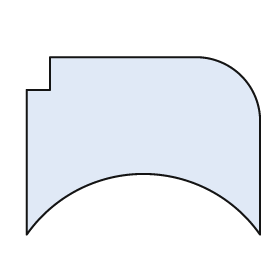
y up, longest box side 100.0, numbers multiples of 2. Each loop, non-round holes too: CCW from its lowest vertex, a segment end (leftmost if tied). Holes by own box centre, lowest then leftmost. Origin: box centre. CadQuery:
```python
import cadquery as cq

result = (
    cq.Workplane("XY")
    .moveTo(-50.0, -38.0)
    .threePointArc((0.0, -12.0), (50.0, -38.0))
    .lineTo(50.0, 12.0)
    .threePointArc((42.0, 30.0), (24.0, 38.0))
    .lineTo(-40.0, 38.0)
    .lineTo(-40.0, 24.0)
    .lineTo(-50.0, 24.0)
    .close()
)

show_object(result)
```